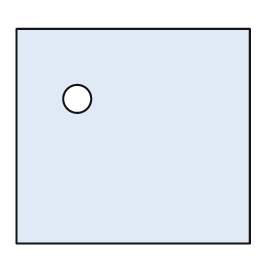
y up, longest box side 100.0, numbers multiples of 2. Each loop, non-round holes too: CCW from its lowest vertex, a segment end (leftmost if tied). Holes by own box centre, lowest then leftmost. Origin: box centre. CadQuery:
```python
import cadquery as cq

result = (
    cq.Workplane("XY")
    .moveTo(-50.0, -46.0)
    .lineTo(50.0, -46.0)
    .lineTo(50.0, 46.0)
    .lineTo(-50.0, 46.0)
    .close()
    .moveTo(-24.0, 16.0)
    .circle(6.0)
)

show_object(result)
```